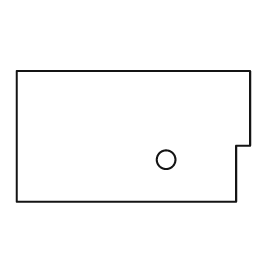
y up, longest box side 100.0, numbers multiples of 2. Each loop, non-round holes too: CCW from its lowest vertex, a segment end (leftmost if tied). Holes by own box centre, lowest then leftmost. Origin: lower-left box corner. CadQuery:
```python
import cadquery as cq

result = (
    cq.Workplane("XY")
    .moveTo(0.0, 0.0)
    .lineTo(94.0, 0.0)
    .lineTo(94.0, 24.0)
    .lineTo(100.0, 24.0)
    .lineTo(100.0, 56.0)
    .lineTo(0.0, 56.0)
    .close()
    .moveTo(64.0, 18.0)
    .circle(4.0)
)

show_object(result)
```